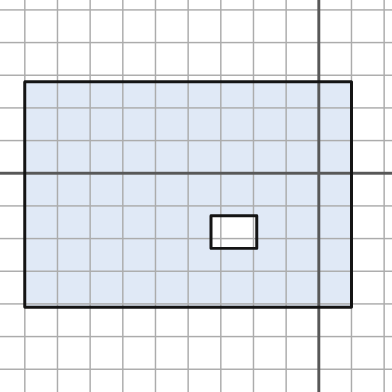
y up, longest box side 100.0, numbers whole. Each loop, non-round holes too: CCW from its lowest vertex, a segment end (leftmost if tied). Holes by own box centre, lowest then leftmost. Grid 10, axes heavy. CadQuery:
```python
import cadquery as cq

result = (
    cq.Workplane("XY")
    .moveTo(-90.0, -41.0)
    .lineTo(10.0, -41.0)
    .lineTo(10.0, 28.0)
    .lineTo(-90.0, 28.0)
    .close()
    .moveTo(-33.0, -23.0)
    .lineTo(-19.0, -23.0)
    .lineTo(-19.0, -13.0)
    .lineTo(-33.0, -13.0)
    .close()
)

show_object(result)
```